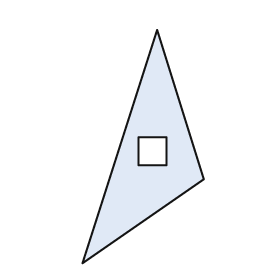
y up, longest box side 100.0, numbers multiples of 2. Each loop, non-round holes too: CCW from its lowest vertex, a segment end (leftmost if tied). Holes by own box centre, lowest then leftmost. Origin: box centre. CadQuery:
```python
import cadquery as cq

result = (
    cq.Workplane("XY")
    .moveTo(-26.0, -50.0)
    .lineTo(26.0, -14.0)
    .lineTo(6.0, 50.0)
    .close()
    .moveTo(-2.0, -8.0)
    .lineTo(10.0, -8.0)
    .lineTo(10.0, 4.0)
    .lineTo(-2.0, 4.0)
    .close()
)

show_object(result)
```